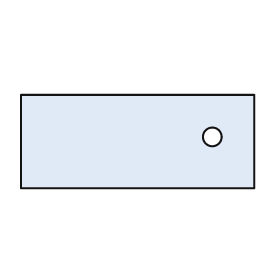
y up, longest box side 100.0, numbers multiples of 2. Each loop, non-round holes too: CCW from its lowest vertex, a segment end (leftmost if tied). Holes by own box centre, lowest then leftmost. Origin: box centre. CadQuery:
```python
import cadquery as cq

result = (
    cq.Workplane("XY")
    .moveTo(-50.0, -20.0)
    .lineTo(50.0, -20.0)
    .lineTo(50.0, 20.0)
    .lineTo(-50.0, 20.0)
    .close()
    .moveTo(32.0, 2.0)
    .circle(4.0)
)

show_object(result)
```